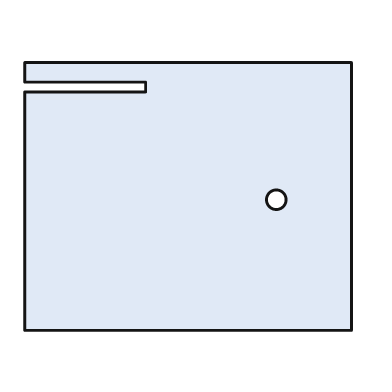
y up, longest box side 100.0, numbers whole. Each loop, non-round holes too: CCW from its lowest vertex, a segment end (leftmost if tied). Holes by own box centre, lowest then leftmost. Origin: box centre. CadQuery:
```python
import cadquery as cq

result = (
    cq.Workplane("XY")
    .moveTo(-50.0, -41.0)
    .lineTo(50.0, -41.0)
    .lineTo(50.0, 41.0)
    .lineTo(-50.0, 41.0)
    .lineTo(-50.0, 35.0)
    .lineTo(-13.0, 35.0)
    .lineTo(-13.0, 32.0)
    .lineTo(-50.0, 32.0)
    .close()
    .moveTo(27.0, -1.0)
    .circle(3.0)
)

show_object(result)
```